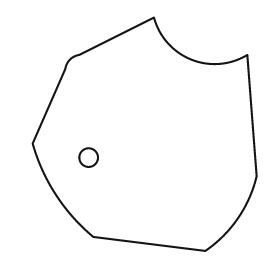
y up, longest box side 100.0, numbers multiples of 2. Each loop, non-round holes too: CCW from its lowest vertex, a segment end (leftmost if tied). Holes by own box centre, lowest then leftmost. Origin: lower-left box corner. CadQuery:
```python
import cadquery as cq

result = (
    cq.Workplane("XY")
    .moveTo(74.0, 0.0)
    .threePointArc((88.0, 14.0), (96.0, 32.0))
    .lineTo(92.0, 84.0)
    .threePointArc((68.0, 82.0), (52.0, 100.0))
    .lineTo(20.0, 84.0)
    .threePointArc((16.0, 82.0), (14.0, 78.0))
    .lineTo(0.0, 46.0)
    .threePointArc((10.0, 24.0), (26.0, 6.0))
    .close()
    .moveTo(24.0, 40.0)
    .circle(4.0)
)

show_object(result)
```